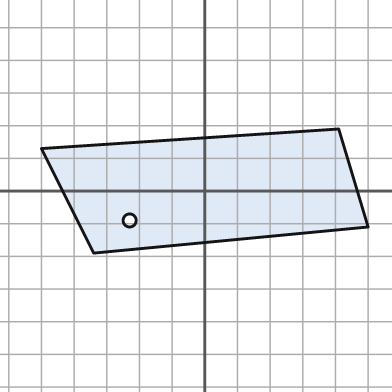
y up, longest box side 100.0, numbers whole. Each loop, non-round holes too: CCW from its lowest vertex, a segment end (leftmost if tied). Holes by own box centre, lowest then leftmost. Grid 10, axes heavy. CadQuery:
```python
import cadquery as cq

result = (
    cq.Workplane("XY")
    .moveTo(-34.0, -19.0)
    .lineTo(50.0, -11.0)
    .lineTo(41.0, 19.0)
    .lineTo(-50.0, 13.0)
    .close()
    .moveTo(-23.0, -9.0)
    .circle(2.0)
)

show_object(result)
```